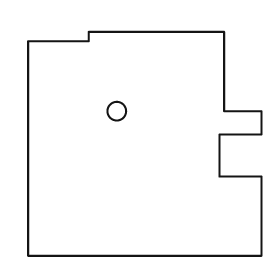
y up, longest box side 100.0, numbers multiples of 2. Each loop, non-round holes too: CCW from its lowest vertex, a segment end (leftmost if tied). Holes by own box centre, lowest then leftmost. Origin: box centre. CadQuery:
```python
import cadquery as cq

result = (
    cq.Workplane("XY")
    .moveTo(-50.0, -48.0)
    .lineTo(50.0, -48.0)
    .lineTo(50.0, -14.0)
    .lineTo(32.0, -14.0)
    .lineTo(32.0, 4.0)
    .lineTo(50.0, 4.0)
    .lineTo(50.0, 14.0)
    .lineTo(34.0, 14.0)
    .lineTo(34.0, 48.0)
    .lineTo(-24.0, 48.0)
    .lineTo(-24.0, 44.0)
    .lineTo(-50.0, 44.0)
    .close()
    .moveTo(-12.0, 14.0)
    .circle(4.0)
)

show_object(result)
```